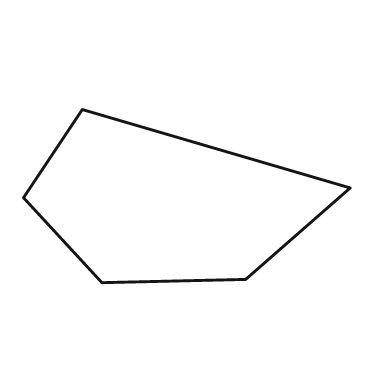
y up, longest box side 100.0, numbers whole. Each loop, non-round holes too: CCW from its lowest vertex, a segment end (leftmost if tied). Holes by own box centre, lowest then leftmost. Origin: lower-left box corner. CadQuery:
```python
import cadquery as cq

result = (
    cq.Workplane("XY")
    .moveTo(24.0, 0.0)
    .lineTo(68.0, 1.0)
    .lineTo(100.0, 29.0)
    .lineTo(18.0, 53.0)
    .lineTo(0.0, 26.0)
    .close()
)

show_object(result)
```